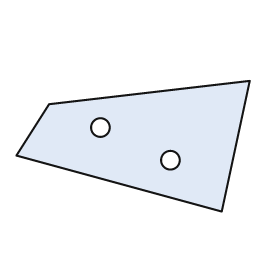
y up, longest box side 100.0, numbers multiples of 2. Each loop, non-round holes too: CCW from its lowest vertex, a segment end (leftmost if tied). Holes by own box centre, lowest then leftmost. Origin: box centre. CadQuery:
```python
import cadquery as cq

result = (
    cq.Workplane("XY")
    .moveTo(38.0, -28.0)
    .lineTo(50.0, 28.0)
    .lineTo(-36.0, 18.0)
    .lineTo(-50.0, -4.0)
    .close()
    .moveTo(16.0, -6.0)
    .circle(4.0)
    .moveTo(-14.0, 8.0)
    .circle(4.0)
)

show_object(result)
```